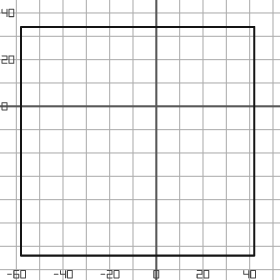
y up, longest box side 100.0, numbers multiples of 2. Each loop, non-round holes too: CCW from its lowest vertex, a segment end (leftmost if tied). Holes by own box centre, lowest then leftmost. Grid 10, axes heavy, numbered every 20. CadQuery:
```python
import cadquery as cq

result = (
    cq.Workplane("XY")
    .moveTo(-58.0, -64.0)
    .lineTo(42.0, -64.0)
    .lineTo(42.0, 34.0)
    .lineTo(-58.0, 34.0)
    .close()
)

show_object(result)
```